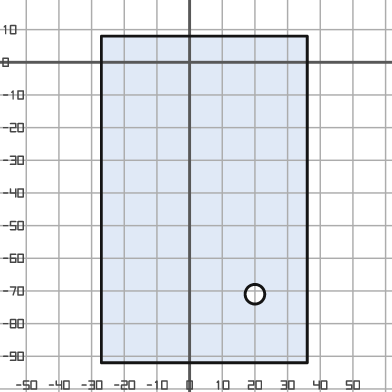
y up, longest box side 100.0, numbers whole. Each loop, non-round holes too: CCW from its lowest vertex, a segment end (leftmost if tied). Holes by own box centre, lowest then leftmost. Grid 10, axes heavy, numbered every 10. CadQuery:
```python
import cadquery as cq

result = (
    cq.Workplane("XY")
    .moveTo(-27.0, -92.0)
    .lineTo(36.0, -92.0)
    .lineTo(36.0, 8.0)
    .lineTo(-27.0, 8.0)
    .close()
    .moveTo(20.0, -71.0)
    .circle(3.0)
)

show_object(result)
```